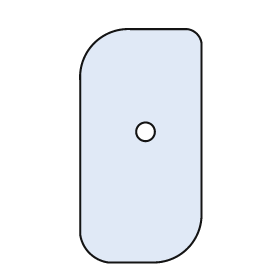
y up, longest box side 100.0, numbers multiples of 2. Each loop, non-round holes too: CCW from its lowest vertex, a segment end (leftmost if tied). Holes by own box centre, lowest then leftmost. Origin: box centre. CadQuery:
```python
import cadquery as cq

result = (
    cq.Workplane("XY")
    .moveTo(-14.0, -50.0)
    .lineTo(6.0, -50.0)
    .threePointArc((20.0, -44.0), (26.0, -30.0))
    .lineTo(26.0, 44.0)
    .threePointArc((24.0, 48.0), (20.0, 50.0))
    .lineTo(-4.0, 50.0)
    .threePointArc((-20.0, 44.0), (-26.0, 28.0))
    .lineTo(-26.0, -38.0)
    .threePointArc((-22.0, -46.0), (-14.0, -50.0))
    .close()
    .moveTo(2.0, 6.0)
    .circle(4.0)
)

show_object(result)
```